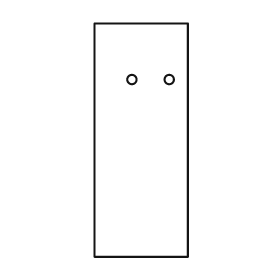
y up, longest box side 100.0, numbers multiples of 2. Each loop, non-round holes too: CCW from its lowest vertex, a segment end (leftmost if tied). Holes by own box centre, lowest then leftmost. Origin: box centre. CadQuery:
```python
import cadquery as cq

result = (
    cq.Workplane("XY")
    .moveTo(-20.0, -50.0)
    .lineTo(20.0, -50.0)
    .lineTo(20.0, 50.0)
    .lineTo(-20.0, 50.0)
    .close()
    .moveTo(-4.0, 26.0)
    .circle(2.0)
    .moveTo(12.0, 26.0)
    .circle(2.0)
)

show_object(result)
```